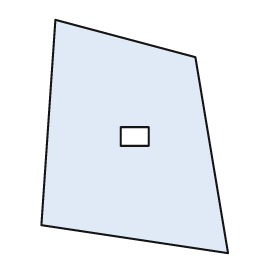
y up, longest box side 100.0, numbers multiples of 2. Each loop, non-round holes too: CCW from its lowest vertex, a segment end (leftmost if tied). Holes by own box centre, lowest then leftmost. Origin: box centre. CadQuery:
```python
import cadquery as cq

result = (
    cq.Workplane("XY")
    .moveTo(40.0, -50.0)
    .lineTo(26.0, 34.0)
    .lineTo(-34.0, 50.0)
    .lineTo(-40.0, -38.0)
    .close()
    .moveTo(-6.0, -4.0)
    .lineTo(6.0, -4.0)
    .lineTo(6.0, 4.0)
    .lineTo(-6.0, 4.0)
    .close()
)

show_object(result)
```